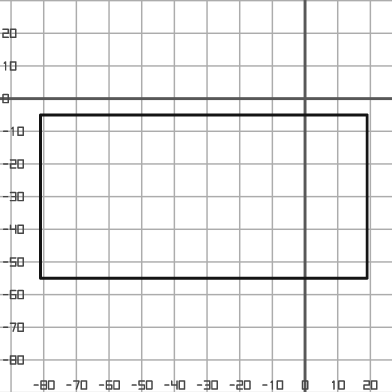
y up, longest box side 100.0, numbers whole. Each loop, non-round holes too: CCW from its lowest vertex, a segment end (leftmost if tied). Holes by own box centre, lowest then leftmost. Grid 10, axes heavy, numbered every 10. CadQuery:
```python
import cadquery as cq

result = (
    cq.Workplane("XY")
    .moveTo(-81.0, -55.0)
    .lineTo(19.0, -55.0)
    .lineTo(19.0, -5.0)
    .lineTo(-81.0, -5.0)
    .close()
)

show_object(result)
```